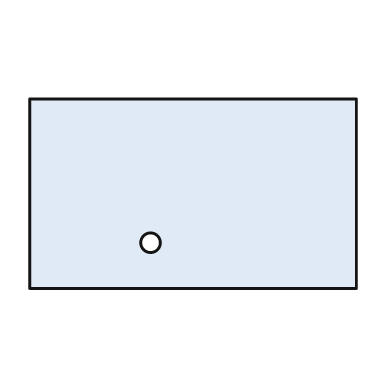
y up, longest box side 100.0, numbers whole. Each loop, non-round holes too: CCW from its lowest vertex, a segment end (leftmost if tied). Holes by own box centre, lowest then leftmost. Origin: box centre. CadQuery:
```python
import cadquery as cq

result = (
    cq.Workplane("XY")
    .moveTo(-50.0, -29.0)
    .lineTo(50.0, -29.0)
    .lineTo(50.0, 29.0)
    .lineTo(-50.0, 29.0)
    .close()
    .moveTo(-13.0, -15.0)
    .circle(3.0)
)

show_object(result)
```